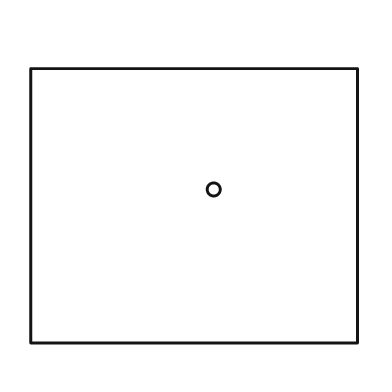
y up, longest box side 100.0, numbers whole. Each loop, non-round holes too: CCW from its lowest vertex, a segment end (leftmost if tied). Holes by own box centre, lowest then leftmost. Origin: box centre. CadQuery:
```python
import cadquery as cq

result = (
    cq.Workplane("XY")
    .moveTo(-50.0, -42.0)
    .lineTo(50.0, -42.0)
    .lineTo(50.0, 42.0)
    .lineTo(-50.0, 42.0)
    .close()
    .moveTo(6.0, 5.0)
    .circle(2.0)
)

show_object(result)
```